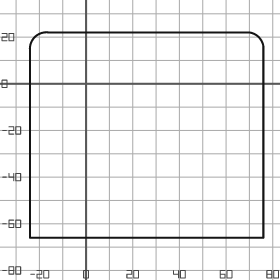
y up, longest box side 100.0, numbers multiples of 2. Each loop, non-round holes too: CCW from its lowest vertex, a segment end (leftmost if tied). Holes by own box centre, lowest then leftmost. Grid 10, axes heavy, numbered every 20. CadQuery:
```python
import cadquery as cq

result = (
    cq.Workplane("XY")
    .moveTo(-24.0, -66.0)
    .lineTo(76.0, -66.0)
    .lineTo(76.0, 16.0)
    .threePointArc((74.0, 20.0), (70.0, 22.0))
    .lineTo(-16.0, 22.0)
    .threePointArc((-22.0, 20.0), (-24.0, 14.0))
    .close()
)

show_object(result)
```